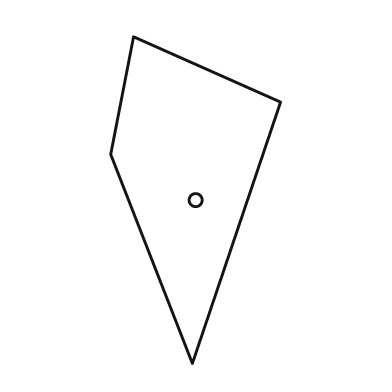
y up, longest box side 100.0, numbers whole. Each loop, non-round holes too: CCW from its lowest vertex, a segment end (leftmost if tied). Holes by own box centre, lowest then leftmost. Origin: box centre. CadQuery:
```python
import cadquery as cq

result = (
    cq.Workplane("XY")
    .moveTo(-1.0, -50.0)
    .lineTo(26.0, 30.0)
    .lineTo(-19.0, 50.0)
    .lineTo(-26.0, 14.0)
    .close()
    .moveTo(0.0, 0.0)
    .circle(2.0)
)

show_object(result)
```